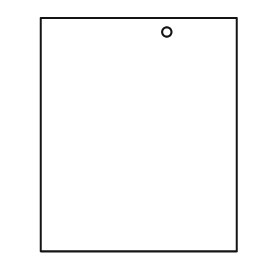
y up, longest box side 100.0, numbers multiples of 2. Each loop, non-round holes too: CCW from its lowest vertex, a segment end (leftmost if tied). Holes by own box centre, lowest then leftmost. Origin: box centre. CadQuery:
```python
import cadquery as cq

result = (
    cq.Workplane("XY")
    .moveTo(-42.0, -50.0)
    .lineTo(42.0, -50.0)
    .lineTo(42.0, 50.0)
    .lineTo(-42.0, 50.0)
    .close()
    .moveTo(12.0, 44.0)
    .circle(2.0)
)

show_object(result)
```